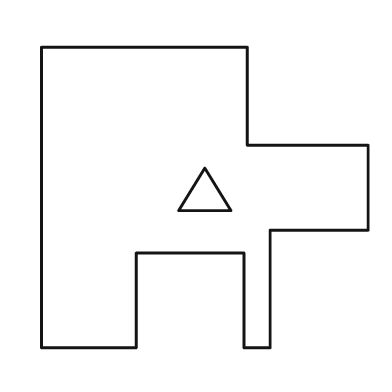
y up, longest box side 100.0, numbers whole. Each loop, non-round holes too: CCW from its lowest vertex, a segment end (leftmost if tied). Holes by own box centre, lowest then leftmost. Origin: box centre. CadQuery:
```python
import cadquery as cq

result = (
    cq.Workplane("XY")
    .moveTo(-50.0, -46.0)
    .lineTo(-21.0, -46.0)
    .lineTo(-21.0, -17.0)
    .lineTo(12.0, -17.0)
    .lineTo(12.0, -46.0)
    .lineTo(20.0, -46.0)
    .lineTo(20.0, -10.0)
    .lineTo(50.0, -10.0)
    .lineTo(50.0, 16.0)
    .lineTo(13.0, 16.0)
    .lineTo(13.0, 46.0)
    .lineTo(-50.0, 46.0)
    .close()
    .moveTo(-8.0, -4.0)
    .lineTo(8.0, -4.0)
    .lineTo(0.0, 9.0)
    .close()
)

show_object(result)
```